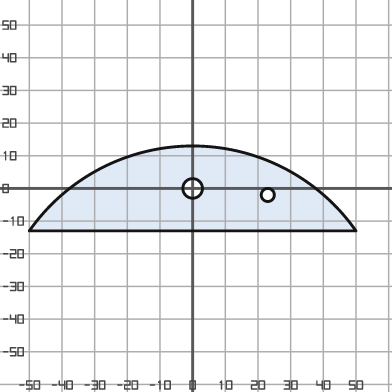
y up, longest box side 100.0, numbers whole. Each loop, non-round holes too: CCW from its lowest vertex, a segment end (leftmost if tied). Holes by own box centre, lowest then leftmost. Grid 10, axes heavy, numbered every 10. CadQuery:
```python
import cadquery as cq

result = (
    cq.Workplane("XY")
    .moveTo(-50.0, -13.0)
    .lineTo(50.0, -13.0)
    .threePointArc((0.0, 13.0), (-50.0, -13.0))
    .close()
    .moveTo(23.0, -2.0)
    .circle(2.0)
    .moveTo(0.0, 0.0)
    .circle(3.0)
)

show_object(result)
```